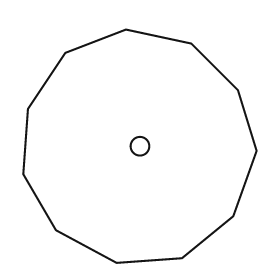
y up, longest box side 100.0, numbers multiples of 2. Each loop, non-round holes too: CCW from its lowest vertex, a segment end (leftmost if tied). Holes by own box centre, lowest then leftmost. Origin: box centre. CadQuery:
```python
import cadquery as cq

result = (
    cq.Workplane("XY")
    .moveTo(-10.0, -50.0)
    .lineTo(18.0, -48.0)
    .lineTo(40.0, -30.0)
    .lineTo(50.0, -2.0)
    .lineTo(42.0, 24.0)
    .lineTo(22.0, 44.0)
    .lineTo(-6.0, 50.0)
    .lineTo(-32.0, 40.0)
    .lineTo(-48.0, 16.0)
    .lineTo(-50.0, -12.0)
    .lineTo(-36.0, -36.0)
    .close()
    .moveTo(0.0, 0.0)
    .circle(4.0)
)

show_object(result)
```